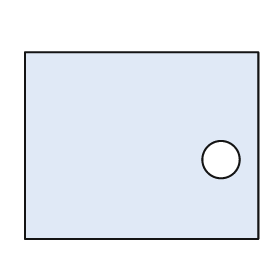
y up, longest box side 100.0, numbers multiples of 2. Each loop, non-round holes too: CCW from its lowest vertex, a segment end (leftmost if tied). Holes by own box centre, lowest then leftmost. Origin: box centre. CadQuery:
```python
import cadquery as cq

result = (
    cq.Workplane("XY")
    .moveTo(-50.0, -40.0)
    .lineTo(50.0, -40.0)
    .lineTo(50.0, 40.0)
    .lineTo(-50.0, 40.0)
    .close()
    .moveTo(34.0, -6.0)
    .circle(8.0)
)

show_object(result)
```